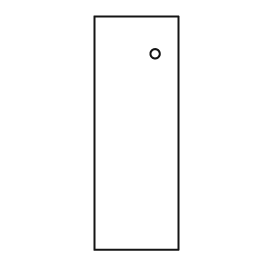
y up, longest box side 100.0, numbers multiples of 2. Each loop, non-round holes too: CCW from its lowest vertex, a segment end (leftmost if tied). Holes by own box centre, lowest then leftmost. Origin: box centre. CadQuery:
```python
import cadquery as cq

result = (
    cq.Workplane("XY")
    .moveTo(-18.0, -50.0)
    .lineTo(18.0, -50.0)
    .lineTo(18.0, 50.0)
    .lineTo(-18.0, 50.0)
    .close()
    .moveTo(8.0, 34.0)
    .circle(2.0)
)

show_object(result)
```